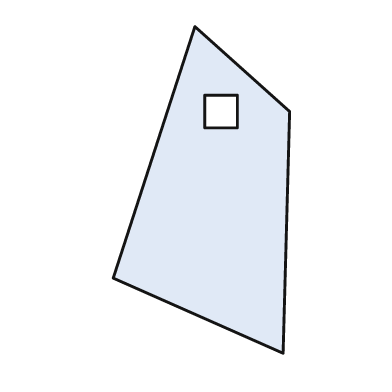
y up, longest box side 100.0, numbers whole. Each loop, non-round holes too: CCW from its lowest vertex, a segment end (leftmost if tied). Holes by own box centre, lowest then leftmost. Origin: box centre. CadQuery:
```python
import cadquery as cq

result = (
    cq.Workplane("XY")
    .moveTo(25.0, -50.0)
    .lineTo(27.0, 24.0)
    .lineTo(-2.0, 50.0)
    .lineTo(-27.0, -27.0)
    .close()
    .moveTo(1.0, 19.0)
    .lineTo(11.0, 19.0)
    .lineTo(11.0, 29.0)
    .lineTo(1.0, 29.0)
    .close()
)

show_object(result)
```